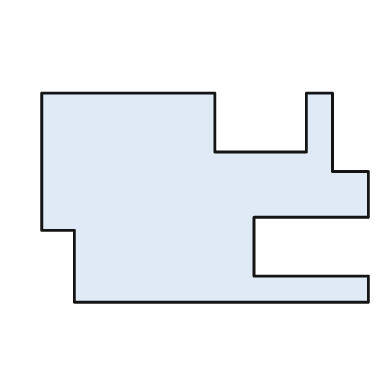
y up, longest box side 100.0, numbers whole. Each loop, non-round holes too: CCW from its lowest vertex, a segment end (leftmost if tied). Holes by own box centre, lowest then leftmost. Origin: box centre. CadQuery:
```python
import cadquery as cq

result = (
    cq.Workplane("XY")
    .moveTo(-40.0, -32.0)
    .lineTo(50.0, -32.0)
    .lineTo(50.0, -24.0)
    .lineTo(15.0, -24.0)
    .lineTo(15.0, -6.0)
    .lineTo(50.0, -6.0)
    .lineTo(50.0, 8.0)
    .lineTo(39.0, 8.0)
    .lineTo(39.0, 32.0)
    .lineTo(31.0, 32.0)
    .lineTo(31.0, 14.0)
    .lineTo(3.0, 14.0)
    .lineTo(3.0, 32.0)
    .lineTo(-50.0, 32.0)
    .lineTo(-50.0, -10.0)
    .lineTo(-40.0, -10.0)
    .close()
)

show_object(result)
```